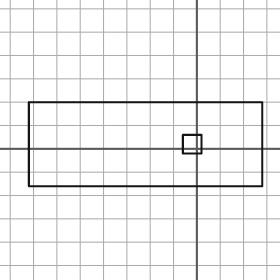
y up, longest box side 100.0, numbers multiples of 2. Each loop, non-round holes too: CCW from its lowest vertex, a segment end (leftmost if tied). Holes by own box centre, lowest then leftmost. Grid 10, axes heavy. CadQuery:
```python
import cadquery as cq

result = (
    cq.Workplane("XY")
    .moveTo(-72.0, -16.0)
    .lineTo(28.0, -16.0)
    .lineTo(28.0, 20.0)
    .lineTo(-72.0, 20.0)
    .close()
    .moveTo(-6.0, -2.0)
    .lineTo(2.0, -2.0)
    .lineTo(2.0, 6.0)
    .lineTo(-6.0, 6.0)
    .close()
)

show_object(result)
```